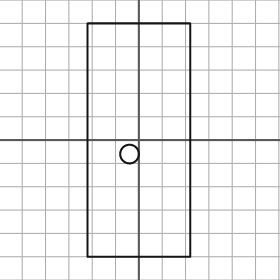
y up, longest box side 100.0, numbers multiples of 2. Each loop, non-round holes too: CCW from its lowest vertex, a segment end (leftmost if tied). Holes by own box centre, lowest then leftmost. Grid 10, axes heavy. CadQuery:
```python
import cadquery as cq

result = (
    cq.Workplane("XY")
    .moveTo(-22.0, -50.0)
    .lineTo(22.0, -50.0)
    .lineTo(22.0, 50.0)
    .lineTo(-22.0, 50.0)
    .close()
    .moveTo(-4.0, -6.0)
    .circle(4.0)
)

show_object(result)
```